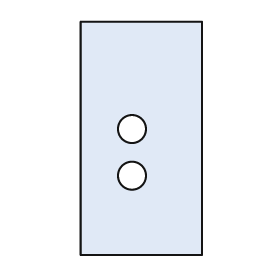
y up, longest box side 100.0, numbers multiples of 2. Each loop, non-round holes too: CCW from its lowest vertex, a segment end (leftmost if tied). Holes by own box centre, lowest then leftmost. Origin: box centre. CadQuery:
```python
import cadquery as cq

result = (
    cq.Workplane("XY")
    .moveTo(-26.0, -50.0)
    .lineTo(26.0, -50.0)
    .lineTo(26.0, 50.0)
    .lineTo(-26.0, 50.0)
    .close()
    .moveTo(-4.0, -16.0)
    .circle(6.0)
    .moveTo(-4.0, 4.0)
    .circle(6.0)
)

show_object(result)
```